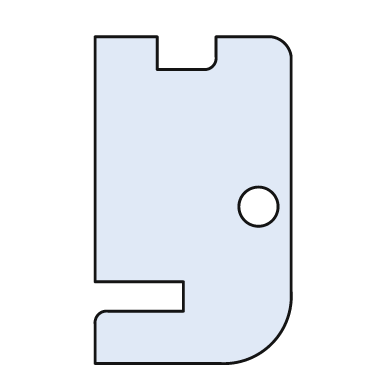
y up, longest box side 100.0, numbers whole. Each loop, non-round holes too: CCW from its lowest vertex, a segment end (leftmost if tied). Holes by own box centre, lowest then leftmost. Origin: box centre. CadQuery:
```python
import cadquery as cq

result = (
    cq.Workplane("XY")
    .moveTo(-30.0, -50.0)
    .lineTo(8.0, -50.0)
    .threePointArc((24.0, -44.0), (30.0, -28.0))
    .lineTo(30.0, 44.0)
    .threePointArc((28.0, 48.0), (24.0, 50.0))
    .lineTo(7.0, 50.0)
    .lineTo(7.0, 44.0)
    .threePointArc((6.0, 41.0), (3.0, 40.0))
    .lineTo(-11.0, 40.0)
    .lineTo(-11.0, 50.0)
    .lineTo(-30.0, 50.0)
    .lineTo(-30.0, -25.0)
    .lineTo(-3.0, -25.0)
    .lineTo(-3.0, -34.0)
    .lineTo(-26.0, -34.0)
    .threePointArc((-29.0, -35.0), (-30.0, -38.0))
    .close()
    .moveTo(20.0, -2.0)
    .circle(6.0)
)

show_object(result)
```